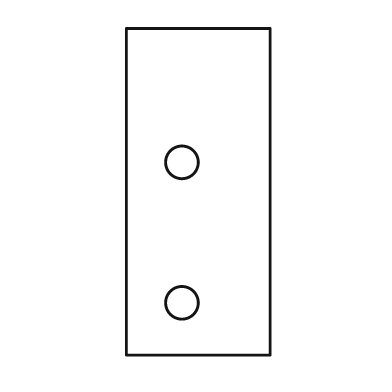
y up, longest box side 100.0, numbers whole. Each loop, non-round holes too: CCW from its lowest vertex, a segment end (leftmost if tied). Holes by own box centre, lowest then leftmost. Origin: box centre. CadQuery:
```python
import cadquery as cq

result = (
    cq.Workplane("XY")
    .moveTo(-22.0, -50.0)
    .lineTo(22.0, -50.0)
    .lineTo(22.0, 50.0)
    .lineTo(-22.0, 50.0)
    .close()
    .moveTo(-5.0, -34.0)
    .circle(5.0)
    .moveTo(-5.0, 9.0)
    .circle(5.0)
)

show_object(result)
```